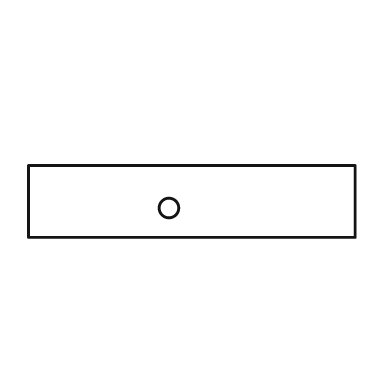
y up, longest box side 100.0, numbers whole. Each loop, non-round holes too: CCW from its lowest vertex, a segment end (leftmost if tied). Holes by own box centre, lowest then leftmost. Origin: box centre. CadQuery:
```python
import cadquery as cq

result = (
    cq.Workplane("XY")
    .moveTo(-50.0, -11.0)
    .lineTo(50.0, -11.0)
    .lineTo(50.0, 11.0)
    .lineTo(-50.0, 11.0)
    .close()
    .moveTo(-7.0, -2.0)
    .circle(3.0)
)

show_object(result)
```